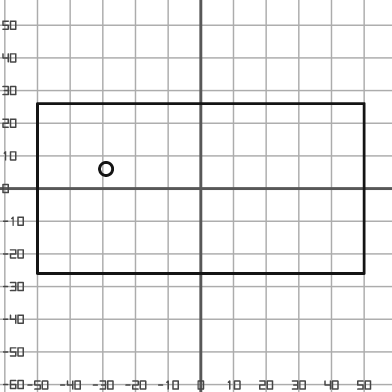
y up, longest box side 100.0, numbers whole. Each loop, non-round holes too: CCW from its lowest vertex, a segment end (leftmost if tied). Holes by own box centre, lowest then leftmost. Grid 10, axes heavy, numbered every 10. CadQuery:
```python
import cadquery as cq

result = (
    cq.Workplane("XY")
    .moveTo(-50.0, -26.0)
    .lineTo(50.0, -26.0)
    .lineTo(50.0, 26.0)
    .lineTo(-50.0, 26.0)
    .close()
    .moveTo(-29.0, 6.0)
    .circle(2.0)
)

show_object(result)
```